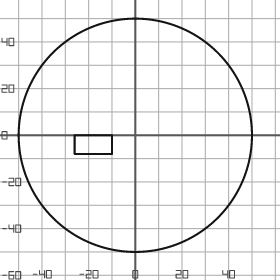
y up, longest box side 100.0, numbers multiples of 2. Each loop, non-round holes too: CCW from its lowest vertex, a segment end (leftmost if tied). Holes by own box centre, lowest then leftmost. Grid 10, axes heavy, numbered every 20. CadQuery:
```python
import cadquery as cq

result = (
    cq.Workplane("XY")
    .moveTo(0.0, 0.0)
    .circle(50.0)
    .moveTo(-26.0, -8.0)
    .lineTo(-10.0, -8.0)
    .lineTo(-10.0, 0.0)
    .lineTo(-26.0, 0.0)
    .close()
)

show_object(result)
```